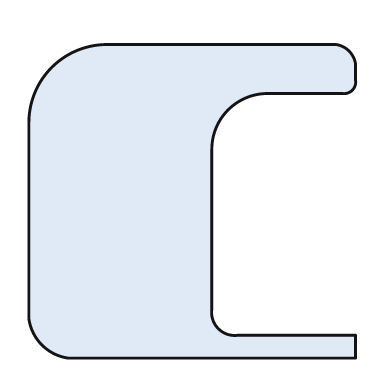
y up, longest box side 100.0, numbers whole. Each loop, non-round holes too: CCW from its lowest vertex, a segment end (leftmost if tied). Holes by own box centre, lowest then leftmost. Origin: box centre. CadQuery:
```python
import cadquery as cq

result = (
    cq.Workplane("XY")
    .moveTo(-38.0, -48.0)
    .lineTo(50.0, -48.0)
    .lineTo(50.0, -41.0)
    .lineTo(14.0, -41.0)
    .threePointArc((8.0, -39.0), (6.0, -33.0))
    .lineTo(6.0, 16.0)
    .threePointArc((11.0, 28.0), (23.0, 33.0))
    .lineTo(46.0, 33.0)
    .threePointArc((49.0, 34.0), (50.0, 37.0))
    .lineTo(50.0, 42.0)
    .threePointArc((48.0, 46.0), (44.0, 48.0))
    .lineTo(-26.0, 48.0)
    .threePointArc((-43.0, 41.0), (-50.0, 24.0))
    .lineTo(-50.0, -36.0)
    .threePointArc((-46.0, -44.0), (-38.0, -48.0))
    .close()
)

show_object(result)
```